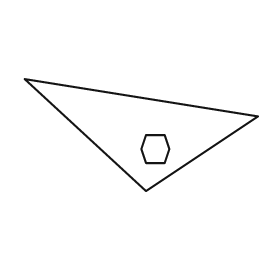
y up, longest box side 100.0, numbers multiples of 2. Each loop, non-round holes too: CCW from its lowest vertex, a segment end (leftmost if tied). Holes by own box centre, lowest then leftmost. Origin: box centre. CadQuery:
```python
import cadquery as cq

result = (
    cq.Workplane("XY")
    .moveTo(2.0, -24.0)
    .lineTo(50.0, 8.0)
    .lineTo(-50.0, 24.0)
    .close()
    .moveTo(2.0, -12.0)
    .lineTo(10.0, -12.0)
    .lineTo(12.0, -6.0)
    .lineTo(10.0, 0.0)
    .lineTo(2.0, 0.0)
    .lineTo(0.0, -6.0)
    .close()
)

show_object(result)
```